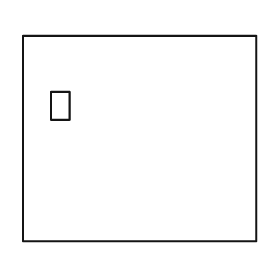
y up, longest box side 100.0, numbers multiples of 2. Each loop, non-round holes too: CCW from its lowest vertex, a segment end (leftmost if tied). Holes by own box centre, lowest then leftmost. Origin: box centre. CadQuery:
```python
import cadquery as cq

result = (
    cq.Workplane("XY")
    .moveTo(-50.0, -44.0)
    .lineTo(50.0, -44.0)
    .lineTo(50.0, 44.0)
    .lineTo(-50.0, 44.0)
    .close()
    .moveTo(-38.0, 8.0)
    .lineTo(-30.0, 8.0)
    .lineTo(-30.0, 20.0)
    .lineTo(-38.0, 20.0)
    .close()
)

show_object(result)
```